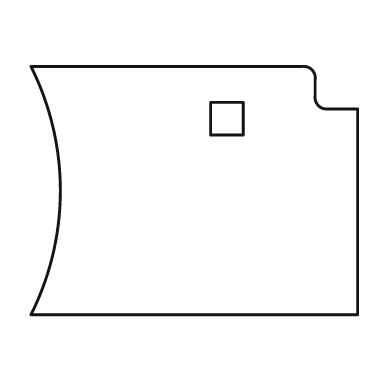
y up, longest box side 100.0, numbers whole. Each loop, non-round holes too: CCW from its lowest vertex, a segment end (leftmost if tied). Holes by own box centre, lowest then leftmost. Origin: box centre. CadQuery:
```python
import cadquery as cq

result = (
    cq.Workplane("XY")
    .moveTo(-50.0, -38.0)
    .lineTo(50.0, -38.0)
    .lineTo(50.0, 25.0)
    .lineTo(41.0, 25.0)
    .threePointArc((38.0, 26.0), (37.0, 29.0))
    .lineTo(37.0, 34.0)
    .threePointArc((36.0, 37.0), (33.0, 38.0))
    .lineTo(-50.0, 38.0)
    .threePointArc((-41.0, 0.0), (-50.0, -38.0))
    .close()
    .moveTo(5.0, 17.0)
    .lineTo(15.0, 17.0)
    .lineTo(15.0, 27.0)
    .lineTo(5.0, 27.0)
    .close()
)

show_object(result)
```